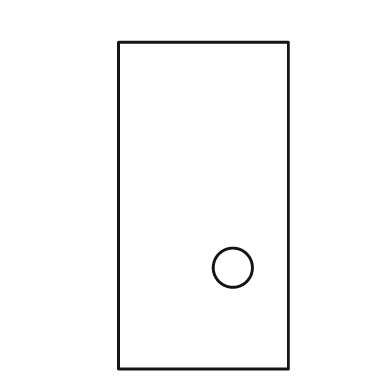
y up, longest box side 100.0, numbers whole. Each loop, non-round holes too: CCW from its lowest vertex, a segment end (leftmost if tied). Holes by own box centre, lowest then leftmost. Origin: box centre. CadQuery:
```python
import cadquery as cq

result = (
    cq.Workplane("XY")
    .moveTo(-26.0, -50.0)
    .lineTo(26.0, -50.0)
    .lineTo(26.0, 50.0)
    .lineTo(-26.0, 50.0)
    .close()
    .moveTo(9.0, -19.0)
    .circle(6.0)
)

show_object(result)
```